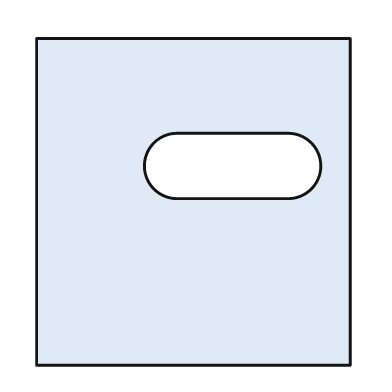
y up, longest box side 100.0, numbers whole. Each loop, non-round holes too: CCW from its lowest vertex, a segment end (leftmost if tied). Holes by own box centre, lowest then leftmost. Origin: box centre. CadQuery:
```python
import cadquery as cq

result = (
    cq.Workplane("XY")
    .moveTo(-48.0, -50.0)
    .lineTo(48.0, -50.0)
    .lineTo(48.0, 50.0)
    .lineTo(-48.0, 50.0)
    .close()
    .moveTo(-5.0, 1.0)
    .lineTo(29.0, 1.0)
    .threePointArc((39.0, 11.0), (29.0, 21.0))
    .lineTo(-5.0, 21.0)
    .threePointArc((-15.0, 11.0), (-5.0, 1.0))
    .close()
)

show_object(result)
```